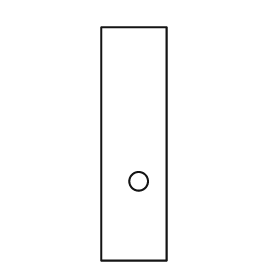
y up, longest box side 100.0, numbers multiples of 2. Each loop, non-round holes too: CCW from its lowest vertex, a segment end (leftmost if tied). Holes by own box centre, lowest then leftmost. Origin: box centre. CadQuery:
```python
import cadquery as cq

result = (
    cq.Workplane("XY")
    .moveTo(-14.0, -50.0)
    .lineTo(14.0, -50.0)
    .lineTo(14.0, 50.0)
    .lineTo(-14.0, 50.0)
    .close()
    .moveTo(2.0, -16.0)
    .circle(4.0)
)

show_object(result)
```